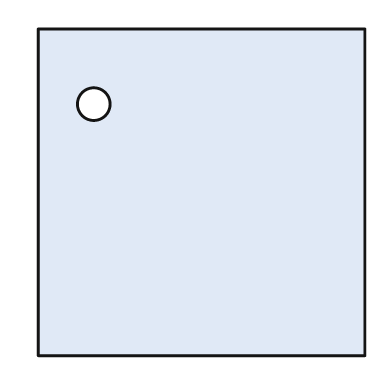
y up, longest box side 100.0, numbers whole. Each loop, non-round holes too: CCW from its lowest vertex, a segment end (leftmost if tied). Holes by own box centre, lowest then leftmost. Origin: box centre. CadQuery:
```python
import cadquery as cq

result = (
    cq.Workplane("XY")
    .moveTo(-50.0, -50.0)
    .lineTo(50.0, -50.0)
    .lineTo(50.0, 50.0)
    .lineTo(-50.0, 50.0)
    .close()
    .moveTo(-33.0, 27.0)
    .circle(5.0)
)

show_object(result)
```